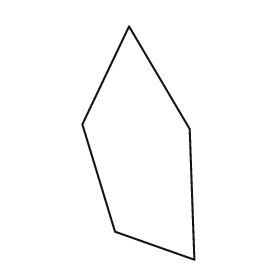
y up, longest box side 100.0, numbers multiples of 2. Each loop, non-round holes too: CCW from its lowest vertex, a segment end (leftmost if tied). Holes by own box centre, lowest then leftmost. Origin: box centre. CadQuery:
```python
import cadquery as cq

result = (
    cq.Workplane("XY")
    .moveTo(24.0, -50.0)
    .lineTo(22.0, 6.0)
    .lineTo(-4.0, 50.0)
    .lineTo(-24.0, 8.0)
    .lineTo(-10.0, -38.0)
    .close()
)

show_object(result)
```